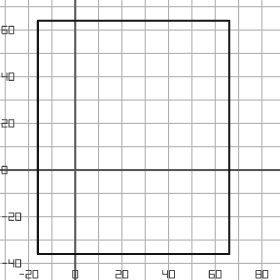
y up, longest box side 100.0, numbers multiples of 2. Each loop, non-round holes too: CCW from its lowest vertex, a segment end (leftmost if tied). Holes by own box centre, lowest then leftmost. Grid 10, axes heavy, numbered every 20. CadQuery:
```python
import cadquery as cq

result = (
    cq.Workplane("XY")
    .moveTo(-16.0, -36.0)
    .lineTo(66.0, -36.0)
    .lineTo(66.0, 64.0)
    .lineTo(-16.0, 64.0)
    .close()
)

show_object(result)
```